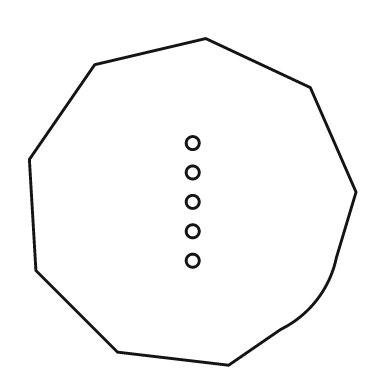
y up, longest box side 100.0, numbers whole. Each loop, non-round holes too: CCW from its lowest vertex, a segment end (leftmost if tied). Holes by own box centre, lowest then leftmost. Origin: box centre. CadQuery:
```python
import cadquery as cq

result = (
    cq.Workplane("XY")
    .moveTo(11.0, -50.0)
    .lineTo(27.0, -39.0)
    .threePointArc((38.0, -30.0), (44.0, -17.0))
    .lineTo(50.0, 3.0)
    .lineTo(36.0, 35.0)
    .lineTo(4.0, 50.0)
    .lineTo(-30.0, 42.0)
    .lineTo(-50.0, 13.0)
    .lineTo(-48.0, -21.0)
    .lineTo(-23.0, -46.0)
    .close()
    .moveTo(0.0, -18.0)
    .circle(2.0)
    .moveTo(0.0, -9.0)
    .circle(2.0)
    .moveTo(0.0, 0.0)
    .circle(2.0)
    .moveTo(0.0, 9.0)
    .circle(2.0)
    .moveTo(0.0, 18.0)
    .circle(2.0)
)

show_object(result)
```